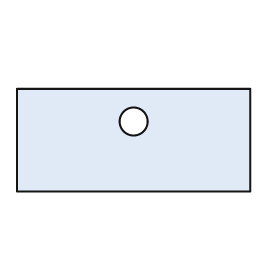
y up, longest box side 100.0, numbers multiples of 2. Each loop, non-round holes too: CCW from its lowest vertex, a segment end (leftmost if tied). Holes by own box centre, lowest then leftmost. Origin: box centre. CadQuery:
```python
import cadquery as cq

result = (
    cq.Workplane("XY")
    .moveTo(-50.0, -22.0)
    .lineTo(50.0, -22.0)
    .lineTo(50.0, 22.0)
    .lineTo(-50.0, 22.0)
    .close()
    .moveTo(0.0, 8.0)
    .circle(6.0)
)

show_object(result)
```